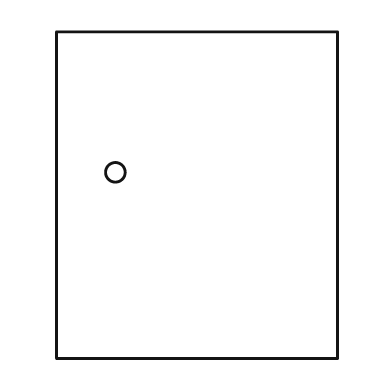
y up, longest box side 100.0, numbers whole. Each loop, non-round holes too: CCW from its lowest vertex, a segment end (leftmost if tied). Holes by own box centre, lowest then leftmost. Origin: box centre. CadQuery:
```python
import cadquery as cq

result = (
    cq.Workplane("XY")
    .moveTo(-43.0, -50.0)
    .lineTo(43.0, -50.0)
    .lineTo(43.0, 50.0)
    .lineTo(-43.0, 50.0)
    .close()
    .moveTo(-25.0, 7.0)
    .circle(3.0)
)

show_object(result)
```